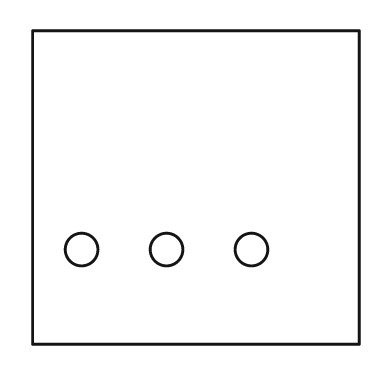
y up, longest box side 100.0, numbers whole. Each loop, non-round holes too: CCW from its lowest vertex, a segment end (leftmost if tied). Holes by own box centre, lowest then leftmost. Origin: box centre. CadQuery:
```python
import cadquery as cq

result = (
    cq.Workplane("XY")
    .moveTo(-50.0, -48.0)
    .lineTo(50.0, -48.0)
    .lineTo(50.0, 48.0)
    .lineTo(-50.0, 48.0)
    .close()
    .moveTo(-35.0, -19.0)
    .circle(5.0)
    .moveTo(-9.0, -19.0)
    .circle(5.0)
    .moveTo(17.0, -19.0)
    .circle(5.0)
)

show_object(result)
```